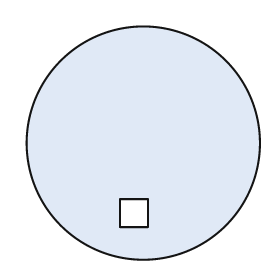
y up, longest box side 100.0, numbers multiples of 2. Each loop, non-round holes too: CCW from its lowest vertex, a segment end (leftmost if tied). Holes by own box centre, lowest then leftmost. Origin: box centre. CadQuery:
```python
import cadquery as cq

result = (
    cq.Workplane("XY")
    .moveTo(0.0, 0.0)
    .circle(50.0)
    .moveTo(-10.0, -36.0)
    .lineTo(2.0, -36.0)
    .lineTo(2.0, -24.0)
    .lineTo(-10.0, -24.0)
    .close()
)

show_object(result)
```